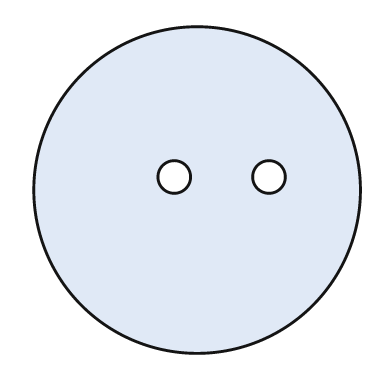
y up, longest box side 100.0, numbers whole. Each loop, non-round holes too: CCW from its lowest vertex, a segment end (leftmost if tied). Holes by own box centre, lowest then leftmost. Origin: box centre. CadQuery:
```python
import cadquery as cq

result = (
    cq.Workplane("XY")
    .moveTo(0.0, 0.0)
    .circle(50.0)
    .moveTo(-7.0, 4.0)
    .circle(5.0)
    .moveTo(22.0, 4.0)
    .circle(5.0)
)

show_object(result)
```